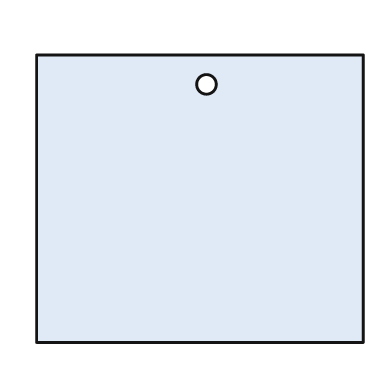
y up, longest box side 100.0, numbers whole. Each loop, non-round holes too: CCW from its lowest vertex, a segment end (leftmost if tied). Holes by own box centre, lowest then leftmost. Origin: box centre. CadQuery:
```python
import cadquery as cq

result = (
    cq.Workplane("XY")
    .moveTo(-50.0, -44.0)
    .lineTo(50.0, -44.0)
    .lineTo(50.0, 44.0)
    .lineTo(-50.0, 44.0)
    .close()
    .moveTo(2.0, 35.0)
    .circle(3.0)
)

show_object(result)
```